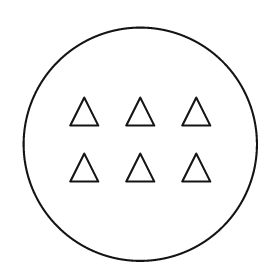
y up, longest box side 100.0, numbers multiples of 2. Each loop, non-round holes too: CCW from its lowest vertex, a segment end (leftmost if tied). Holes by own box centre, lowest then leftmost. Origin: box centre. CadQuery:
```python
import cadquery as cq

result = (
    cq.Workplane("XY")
    .moveTo(0.0, 0.0)
    .circle(50.0)
    .moveTo(-30.0, -16.0)
    .lineTo(-18.0, -16.0)
    .lineTo(-24.0, -4.0)
    .close()
    .moveTo(-6.0, -16.0)
    .lineTo(6.0, -16.0)
    .lineTo(0.0, -4.0)
    .close()
    .moveTo(18.0, -16.0)
    .lineTo(30.0, -16.0)
    .lineTo(24.0, -4.0)
    .close()
    .moveTo(-30.0, 8.0)
    .lineTo(-18.0, 8.0)
    .lineTo(-24.0, 20.0)
    .close()
    .moveTo(-6.0, 8.0)
    .lineTo(6.0, 8.0)
    .lineTo(0.0, 20.0)
    .close()
    .moveTo(18.0, 8.0)
    .lineTo(30.0, 8.0)
    .lineTo(24.0, 20.0)
    .close()
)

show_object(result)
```